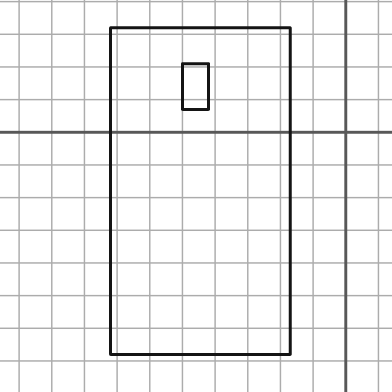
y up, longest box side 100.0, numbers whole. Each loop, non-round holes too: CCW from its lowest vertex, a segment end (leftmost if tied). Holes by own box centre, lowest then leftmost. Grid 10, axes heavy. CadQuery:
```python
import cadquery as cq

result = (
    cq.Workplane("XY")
    .moveTo(-72.0, -68.0)
    .lineTo(-17.0, -68.0)
    .lineTo(-17.0, 32.0)
    .lineTo(-72.0, 32.0)
    .close()
    .moveTo(-50.0, 7.0)
    .lineTo(-42.0, 7.0)
    .lineTo(-42.0, 21.0)
    .lineTo(-50.0, 21.0)
    .close()
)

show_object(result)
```